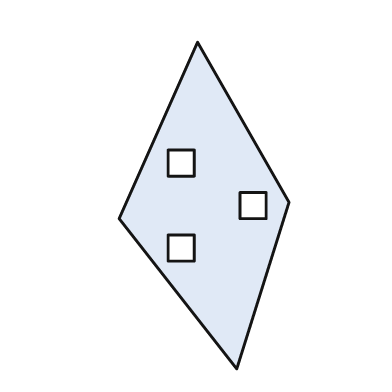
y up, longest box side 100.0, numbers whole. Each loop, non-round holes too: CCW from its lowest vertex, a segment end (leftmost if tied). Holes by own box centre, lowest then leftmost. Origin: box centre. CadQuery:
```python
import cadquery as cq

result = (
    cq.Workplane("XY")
    .moveTo(10.0, -50.0)
    .lineTo(26.0, 1.0)
    .lineTo(-2.0, 50.0)
    .lineTo(-26.0, -4.0)
    .close()
    .moveTo(-11.0, -17.0)
    .lineTo(-3.0, -17.0)
    .lineTo(-3.0, -9.0)
    .lineTo(-11.0, -9.0)
    .close()
    .moveTo(11.0, -4.0)
    .lineTo(19.0, -4.0)
    .lineTo(19.0, 4.0)
    .lineTo(11.0, 4.0)
    .close()
    .moveTo(-11.0, 9.0)
    .lineTo(-3.0, 9.0)
    .lineTo(-3.0, 17.0)
    .lineTo(-11.0, 17.0)
    .close()
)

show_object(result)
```